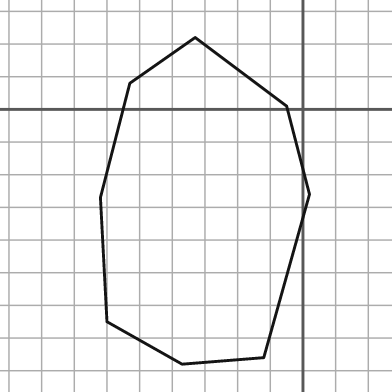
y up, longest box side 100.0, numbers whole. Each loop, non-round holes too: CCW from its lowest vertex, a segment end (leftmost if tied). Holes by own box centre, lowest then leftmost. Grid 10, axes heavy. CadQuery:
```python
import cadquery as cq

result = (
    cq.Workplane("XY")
    .moveTo(-37.0, -78.0)
    .lineTo(-12.0, -76.0)
    .lineTo(2.0, -26.0)
    .lineTo(-5.0, 1.0)
    .lineTo(-33.0, 22.0)
    .lineTo(-53.0, 8.0)
    .lineTo(-62.0, -27.0)
    .lineTo(-60.0, -65.0)
    .close()
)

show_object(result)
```